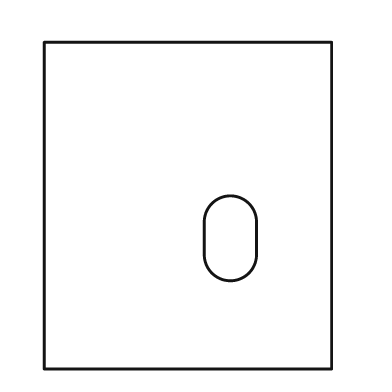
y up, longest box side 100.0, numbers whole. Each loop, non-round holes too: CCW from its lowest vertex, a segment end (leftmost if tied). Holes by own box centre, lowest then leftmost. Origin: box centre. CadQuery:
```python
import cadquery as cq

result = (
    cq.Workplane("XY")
    .moveTo(-44.0, -50.0)
    .lineTo(44.0, -50.0)
    .lineTo(44.0, 50.0)
    .lineTo(-44.0, 50.0)
    .close()
    .moveTo(5.0, -15.0)
    .threePointArc((13.0, -23.0), (21.0, -15.0))
    .lineTo(21.0, -5.0)
    .threePointArc((13.0, 3.0), (5.0, -5.0))
    .close()
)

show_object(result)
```